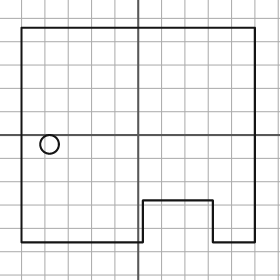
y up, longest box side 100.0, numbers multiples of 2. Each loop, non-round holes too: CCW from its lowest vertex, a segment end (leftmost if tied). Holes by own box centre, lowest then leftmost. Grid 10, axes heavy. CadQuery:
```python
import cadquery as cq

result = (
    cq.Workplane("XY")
    .moveTo(-50.0, -46.0)
    .lineTo(2.0, -46.0)
    .lineTo(2.0, -28.0)
    .lineTo(32.0, -28.0)
    .lineTo(32.0, -46.0)
    .lineTo(50.0, -46.0)
    .lineTo(50.0, 46.0)
    .lineTo(-50.0, 46.0)
    .close()
    .moveTo(-38.0, -4.0)
    .circle(4.0)
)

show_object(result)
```